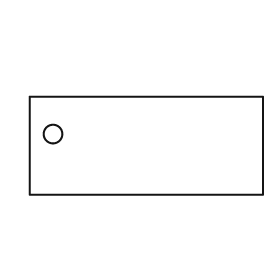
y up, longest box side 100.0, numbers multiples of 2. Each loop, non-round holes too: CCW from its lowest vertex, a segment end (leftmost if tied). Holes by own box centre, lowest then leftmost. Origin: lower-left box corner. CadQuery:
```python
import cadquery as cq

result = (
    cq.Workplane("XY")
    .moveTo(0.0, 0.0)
    .lineTo(100.0, 0.0)
    .lineTo(100.0, 42.0)
    .lineTo(0.0, 42.0)
    .close()
    .moveTo(10.0, 26.0)
    .circle(4.0)
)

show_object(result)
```